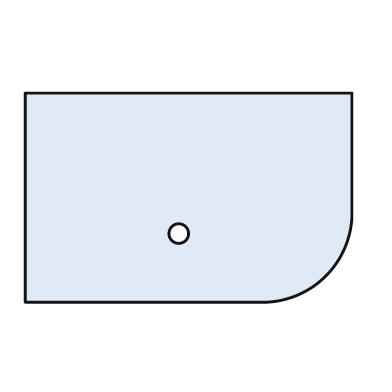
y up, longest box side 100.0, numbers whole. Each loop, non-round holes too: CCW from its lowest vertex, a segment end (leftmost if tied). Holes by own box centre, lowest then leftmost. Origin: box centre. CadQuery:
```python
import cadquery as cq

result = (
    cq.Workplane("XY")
    .moveTo(-50.0, -32.0)
    .lineTo(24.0, -32.0)
    .threePointArc((42.0, -24.0), (50.0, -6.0))
    .lineTo(50.0, 32.0)
    .lineTo(-50.0, 32.0)
    .close()
    .moveTo(-3.0, -11.0)
    .circle(3.0)
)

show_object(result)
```